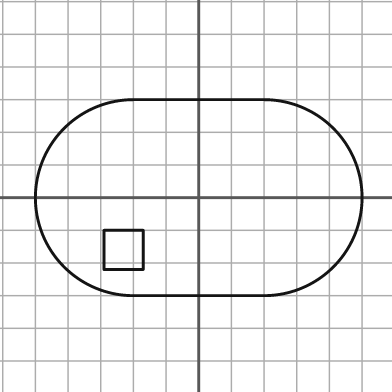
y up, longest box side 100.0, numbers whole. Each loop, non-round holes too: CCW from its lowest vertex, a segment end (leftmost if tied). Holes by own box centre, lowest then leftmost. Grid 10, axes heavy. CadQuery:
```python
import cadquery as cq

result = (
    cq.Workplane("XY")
    .moveTo(-20.0, -30.0)
    .lineTo(20.0, -30.0)
    .threePointArc((50.0, 0.0), (20.0, 30.0))
    .lineTo(-20.0, 30.0)
    .threePointArc((-50.0, 0.0), (-20.0, -30.0))
    .close()
    .moveTo(-29.0, -22.0)
    .lineTo(-17.0, -22.0)
    .lineTo(-17.0, -10.0)
    .lineTo(-29.0, -10.0)
    .close()
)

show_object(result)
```